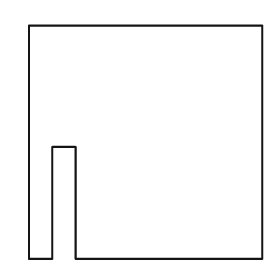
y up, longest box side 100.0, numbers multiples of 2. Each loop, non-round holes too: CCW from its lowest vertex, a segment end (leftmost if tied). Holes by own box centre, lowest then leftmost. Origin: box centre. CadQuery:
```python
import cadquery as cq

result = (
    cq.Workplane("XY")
    .moveTo(-50.0, -50.0)
    .lineTo(-40.0, -50.0)
    .lineTo(-40.0, -2.0)
    .lineTo(-30.0, -2.0)
    .lineTo(-30.0, -50.0)
    .lineTo(50.0, -50.0)
    .lineTo(50.0, 50.0)
    .lineTo(-50.0, 50.0)
    .close()
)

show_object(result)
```